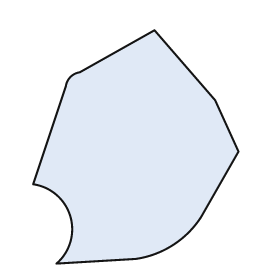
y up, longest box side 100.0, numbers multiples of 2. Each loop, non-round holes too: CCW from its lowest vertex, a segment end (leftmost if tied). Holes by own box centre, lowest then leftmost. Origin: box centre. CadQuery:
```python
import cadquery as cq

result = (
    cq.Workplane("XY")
    .moveTo(-34.0, -50.0)
    .lineTo(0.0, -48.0)
    .threePointArc((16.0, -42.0), (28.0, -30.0))
    .lineTo(44.0, -2.0)
    .lineTo(34.0, 20.0)
    .lineTo(8.0, 50.0)
    .lineTo(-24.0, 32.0)
    .threePointArc((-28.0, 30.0), (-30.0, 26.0))
    .lineTo(-44.0, -16.0)
    .threePointArc((-28.0, -30.0), (-34.0, -50.0))
    .close()
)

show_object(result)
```